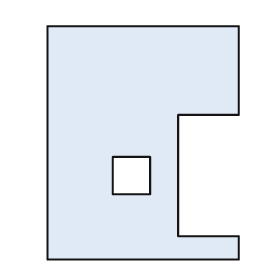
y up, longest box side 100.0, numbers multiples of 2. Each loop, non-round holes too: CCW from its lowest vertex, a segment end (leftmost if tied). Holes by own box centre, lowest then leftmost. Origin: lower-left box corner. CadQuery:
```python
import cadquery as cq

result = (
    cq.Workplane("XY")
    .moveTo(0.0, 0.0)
    .lineTo(82.0, 0.0)
    .lineTo(82.0, 10.0)
    .lineTo(56.0, 10.0)
    .lineTo(56.0, 62.0)
    .lineTo(82.0, 62.0)
    .lineTo(82.0, 100.0)
    .lineTo(0.0, 100.0)
    .close()
    .moveTo(28.0, 28.0)
    .lineTo(44.0, 28.0)
    .lineTo(44.0, 44.0)
    .lineTo(28.0, 44.0)
    .close()
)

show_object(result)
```